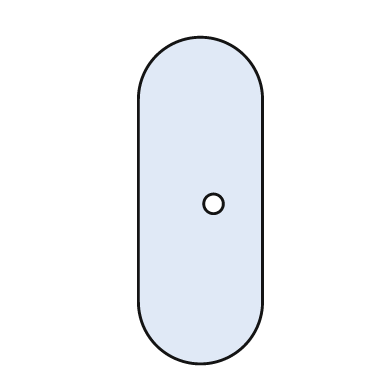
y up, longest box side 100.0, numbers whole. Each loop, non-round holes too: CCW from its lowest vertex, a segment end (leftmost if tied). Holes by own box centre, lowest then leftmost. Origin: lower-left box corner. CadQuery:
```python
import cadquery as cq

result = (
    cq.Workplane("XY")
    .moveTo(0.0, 19.0)
    .threePointArc((19.0, 0.0), (38.0, 19.0))
    .lineTo(38.0, 81.0)
    .threePointArc((19.0, 100.0), (0.0, 81.0))
    .close()
    .moveTo(23.0, 49.0)
    .circle(3.0)
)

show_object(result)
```